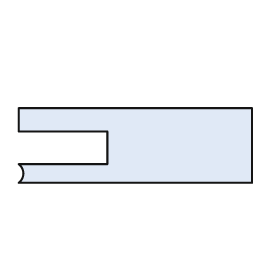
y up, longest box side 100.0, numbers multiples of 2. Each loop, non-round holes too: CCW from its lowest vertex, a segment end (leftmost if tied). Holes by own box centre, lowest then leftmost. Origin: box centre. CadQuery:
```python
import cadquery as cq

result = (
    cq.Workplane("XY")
    .moveTo(-50.0, -16.0)
    .lineTo(50.0, -16.0)
    .lineTo(50.0, 16.0)
    .lineTo(-50.0, 16.0)
    .lineTo(-50.0, 6.0)
    .lineTo(-12.0, 6.0)
    .lineTo(-12.0, -8.0)
    .lineTo(-50.0, -8.0)
    .threePointArc((-48.0, -12.0), (-50.0, -16.0))
    .close()
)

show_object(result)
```